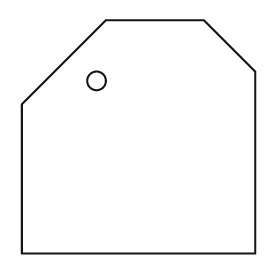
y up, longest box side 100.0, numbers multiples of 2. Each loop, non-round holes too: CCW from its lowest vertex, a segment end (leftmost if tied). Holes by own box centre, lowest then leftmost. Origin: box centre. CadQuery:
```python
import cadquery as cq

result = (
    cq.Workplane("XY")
    .moveTo(-50.0, -50.0)
    .lineTo(50.0, -50.0)
    .lineTo(50.0, 28.0)
    .lineTo(28.0, 50.0)
    .lineTo(-14.0, 50.0)
    .lineTo(-50.0, 14.0)
    .close()
    .moveTo(-18.0, 24.0)
    .circle(4.0)
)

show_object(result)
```